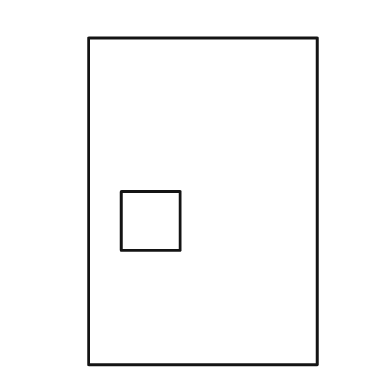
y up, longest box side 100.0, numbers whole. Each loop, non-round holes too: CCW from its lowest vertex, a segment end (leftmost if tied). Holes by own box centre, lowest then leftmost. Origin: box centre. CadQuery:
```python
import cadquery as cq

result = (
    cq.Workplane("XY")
    .moveTo(-35.0, -50.0)
    .lineTo(35.0, -50.0)
    .lineTo(35.0, 50.0)
    .lineTo(-35.0, 50.0)
    .close()
    .moveTo(-25.0, -15.0)
    .lineTo(-7.0, -15.0)
    .lineTo(-7.0, 3.0)
    .lineTo(-25.0, 3.0)
    .close()
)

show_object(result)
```